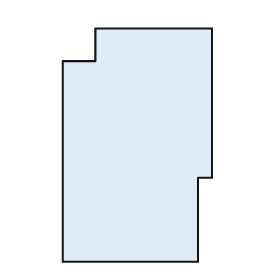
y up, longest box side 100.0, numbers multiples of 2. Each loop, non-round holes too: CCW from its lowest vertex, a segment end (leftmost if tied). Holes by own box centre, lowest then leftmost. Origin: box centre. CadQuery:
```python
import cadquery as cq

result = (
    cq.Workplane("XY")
    .moveTo(-32.0, -50.0)
    .lineTo(26.0, -50.0)
    .lineTo(26.0, -14.0)
    .lineTo(32.0, -14.0)
    .lineTo(32.0, 50.0)
    .lineTo(-18.0, 50.0)
    .lineTo(-18.0, 36.0)
    .lineTo(-32.0, 36.0)
    .close()
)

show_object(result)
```